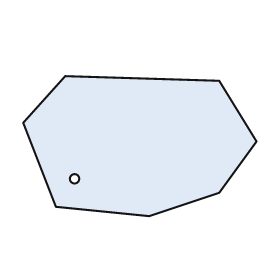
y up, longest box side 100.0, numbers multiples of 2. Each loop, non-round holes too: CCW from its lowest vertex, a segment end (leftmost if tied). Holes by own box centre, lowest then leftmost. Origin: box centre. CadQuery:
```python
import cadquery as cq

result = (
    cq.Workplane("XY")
    .moveTo(4.0, -30.0)
    .lineTo(34.0, -20.0)
    .lineTo(50.0, 2.0)
    .lineTo(34.0, 28.0)
    .lineTo(-32.0, 30.0)
    .lineTo(-50.0, 10.0)
    .lineTo(-36.0, -26.0)
    .close()
    .moveTo(-28.0, -14.0)
    .circle(2.0)
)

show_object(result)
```